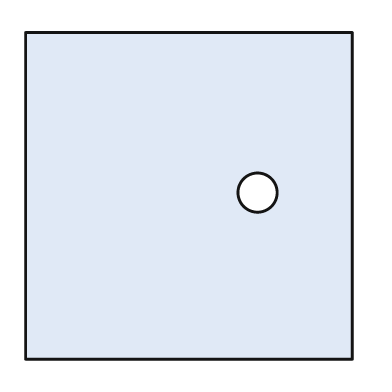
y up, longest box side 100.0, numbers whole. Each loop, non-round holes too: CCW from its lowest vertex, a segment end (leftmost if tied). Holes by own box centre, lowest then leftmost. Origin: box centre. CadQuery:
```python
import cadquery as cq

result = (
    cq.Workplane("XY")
    .moveTo(-50.0, -50.0)
    .lineTo(50.0, -50.0)
    .lineTo(50.0, 50.0)
    .lineTo(-50.0, 50.0)
    .close()
    .moveTo(21.0, 1.0)
    .circle(6.0)
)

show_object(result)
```